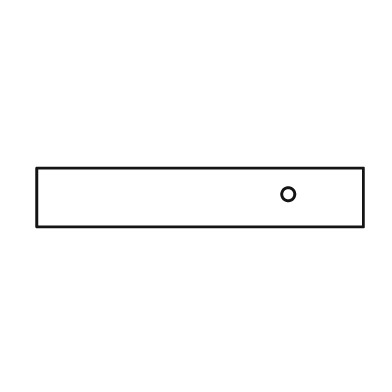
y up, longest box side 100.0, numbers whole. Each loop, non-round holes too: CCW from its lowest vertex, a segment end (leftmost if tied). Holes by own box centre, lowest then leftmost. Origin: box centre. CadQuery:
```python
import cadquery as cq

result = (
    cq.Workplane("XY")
    .moveTo(-50.0, -9.0)
    .lineTo(50.0, -9.0)
    .lineTo(50.0, 9.0)
    .lineTo(-50.0, 9.0)
    .close()
    .moveTo(27.0, 1.0)
    .circle(2.0)
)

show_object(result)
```